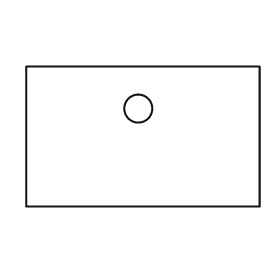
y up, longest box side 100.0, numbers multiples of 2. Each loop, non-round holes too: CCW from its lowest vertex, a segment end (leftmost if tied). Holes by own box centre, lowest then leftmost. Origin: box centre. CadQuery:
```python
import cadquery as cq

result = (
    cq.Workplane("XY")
    .moveTo(-50.0, -30.0)
    .lineTo(50.0, -30.0)
    .lineTo(50.0, 30.0)
    .lineTo(-50.0, 30.0)
    .close()
    .moveTo(-2.0, 12.0)
    .circle(6.0)
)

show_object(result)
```